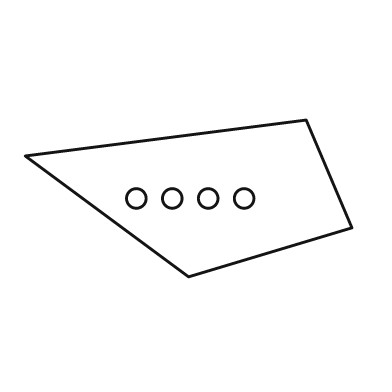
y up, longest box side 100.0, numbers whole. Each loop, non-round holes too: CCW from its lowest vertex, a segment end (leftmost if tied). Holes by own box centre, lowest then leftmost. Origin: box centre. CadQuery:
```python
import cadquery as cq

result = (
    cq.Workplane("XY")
    .moveTo(0.0, -24.0)
    .lineTo(50.0, -9.0)
    .lineTo(36.0, 24.0)
    .lineTo(-50.0, 13.0)
    .close()
    .moveTo(-16.0, 0.0)
    .circle(3.0)
    .moveTo(-5.0, 0.0)
    .circle(3.0)
    .moveTo(6.0, 0.0)
    .circle(3.0)
    .moveTo(17.0, 0.0)
    .circle(3.0)
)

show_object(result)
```